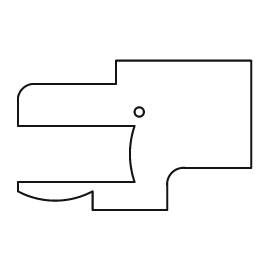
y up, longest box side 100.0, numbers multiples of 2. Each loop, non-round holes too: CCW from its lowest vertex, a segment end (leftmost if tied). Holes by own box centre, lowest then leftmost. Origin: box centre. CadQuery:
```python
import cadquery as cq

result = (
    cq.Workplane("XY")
    .moveTo(-18.0, -32.0)
    .lineTo(14.0, -32.0)
    .lineTo(14.0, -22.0)
    .threePointArc((16.0, -16.0), (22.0, -14.0))
    .lineTo(50.0, -14.0)
    .lineTo(50.0, 32.0)
    .lineTo(-8.0, 32.0)
    .lineTo(-8.0, 22.0)
    .lineTo(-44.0, 22.0)
    .threePointArc((-48.0, 20.0), (-50.0, 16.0))
    .lineTo(-50.0, 4.0)
    .lineTo(0.0, 4.0)
    .threePointArc((-2.0, -8.0), (0.0, -20.0))
    .lineTo(-50.0, -20.0)
    .lineTo(-50.0, -24.0)
    .threePointArc((-34.0, -28.0), (-18.0, -24.0))
    .close()
    .moveTo(2.0, 10.0)
    .circle(2.0)
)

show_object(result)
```